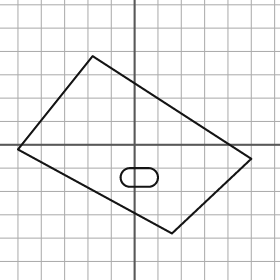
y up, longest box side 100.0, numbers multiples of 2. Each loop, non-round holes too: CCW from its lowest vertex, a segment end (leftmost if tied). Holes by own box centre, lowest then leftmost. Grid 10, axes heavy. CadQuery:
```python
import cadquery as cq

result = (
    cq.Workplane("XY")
    .moveTo(16.0, -38.0)
    .lineTo(50.0, -6.0)
    .lineTo(-18.0, 38.0)
    .lineTo(-50.0, -2.0)
    .close()
    .moveTo(-2.0, -18.0)
    .lineTo(6.0, -18.0)
    .threePointArc((10.0, -14.0), (6.0, -10.0))
    .lineTo(-2.0, -10.0)
    .threePointArc((-6.0, -14.0), (-2.0, -18.0))
    .close()
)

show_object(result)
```